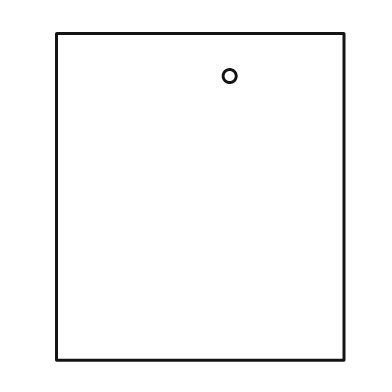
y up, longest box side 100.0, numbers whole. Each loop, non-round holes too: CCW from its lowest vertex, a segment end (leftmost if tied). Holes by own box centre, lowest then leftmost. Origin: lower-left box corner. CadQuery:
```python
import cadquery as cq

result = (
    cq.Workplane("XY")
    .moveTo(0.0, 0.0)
    .lineTo(88.0, 0.0)
    .lineTo(88.0, 100.0)
    .lineTo(0.0, 100.0)
    .close()
    .moveTo(53.0, 87.0)
    .circle(2.0)
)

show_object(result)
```